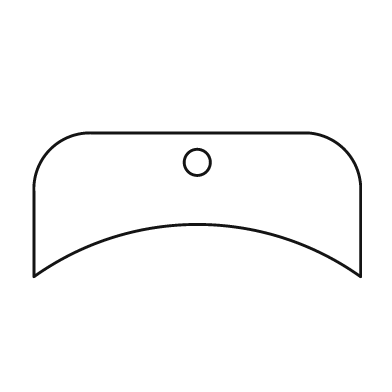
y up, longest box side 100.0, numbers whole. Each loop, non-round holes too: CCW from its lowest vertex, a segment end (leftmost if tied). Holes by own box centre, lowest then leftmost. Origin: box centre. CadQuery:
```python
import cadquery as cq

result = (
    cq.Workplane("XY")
    .moveTo(-50.0, -22.0)
    .threePointArc((0.0, -6.0), (50.0, -22.0))
    .lineTo(50.0, 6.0)
    .threePointArc((45.0, 17.0), (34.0, 22.0))
    .lineTo(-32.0, 22.0)
    .threePointArc((-45.0, 17.0), (-50.0, 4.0))
    .close()
    .moveTo(0.0, 13.0)
    .circle(4.0)
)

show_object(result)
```